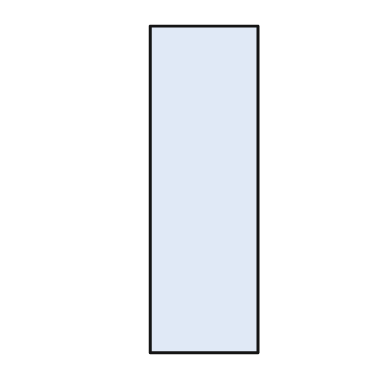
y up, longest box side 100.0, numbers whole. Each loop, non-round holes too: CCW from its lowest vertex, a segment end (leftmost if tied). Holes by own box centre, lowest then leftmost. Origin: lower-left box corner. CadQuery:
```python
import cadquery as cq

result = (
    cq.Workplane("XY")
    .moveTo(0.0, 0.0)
    .lineTo(33.0, 0.0)
    .lineTo(33.0, 100.0)
    .lineTo(0.0, 100.0)
    .close()
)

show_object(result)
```